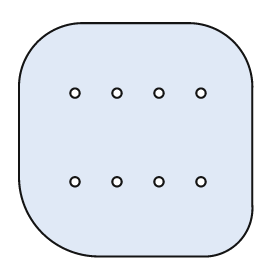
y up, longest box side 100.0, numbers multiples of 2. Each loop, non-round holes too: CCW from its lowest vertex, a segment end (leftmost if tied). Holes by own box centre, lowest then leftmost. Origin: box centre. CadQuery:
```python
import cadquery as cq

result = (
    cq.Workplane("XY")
    .moveTo(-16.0, -50.0)
    .lineTo(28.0, -50.0)
    .threePointArc((44.0, -44.0), (50.0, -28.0))
    .lineTo(50.0, 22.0)
    .threePointArc((42.0, 42.0), (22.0, 50.0))
    .lineTo(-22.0, 50.0)
    .threePointArc((-42.0, 42.0), (-50.0, 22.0))
    .lineTo(-50.0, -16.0)
    .threePointArc((-40.0, -40.0), (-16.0, -50.0))
    .close()
    .moveTo(-26.0, -18.0)
    .circle(2.0)
    .moveTo(-8.0, -18.0)
    .circle(2.0)
    .moveTo(10.0, -18.0)
    .circle(2.0)
    .moveTo(28.0, -18.0)
    .circle(2.0)
    .moveTo(-26.0, 20.0)
    .circle(2.0)
    .moveTo(-8.0, 20.0)
    .circle(2.0)
    .moveTo(10.0, 20.0)
    .circle(2.0)
    .moveTo(28.0, 20.0)
    .circle(2.0)
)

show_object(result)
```